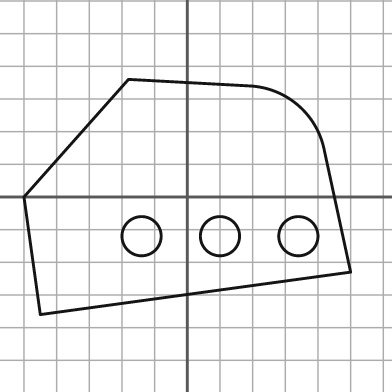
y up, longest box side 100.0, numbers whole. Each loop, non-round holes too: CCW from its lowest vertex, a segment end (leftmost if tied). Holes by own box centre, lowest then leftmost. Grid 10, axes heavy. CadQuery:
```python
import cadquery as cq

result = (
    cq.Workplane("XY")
    .moveTo(-45.0, -36.0)
    .lineTo(50.0, -23.0)
    .lineTo(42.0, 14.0)
    .threePointArc((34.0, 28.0), (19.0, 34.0))
    .lineTo(-18.0, 36.0)
    .lineTo(-50.0, 0.0)
    .close()
    .moveTo(-14.0, -12.0)
    .circle(6.0)
    .moveTo(10.0, -12.0)
    .circle(6.0)
    .moveTo(34.0, -12.0)
    .circle(6.0)
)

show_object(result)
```